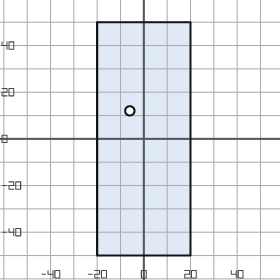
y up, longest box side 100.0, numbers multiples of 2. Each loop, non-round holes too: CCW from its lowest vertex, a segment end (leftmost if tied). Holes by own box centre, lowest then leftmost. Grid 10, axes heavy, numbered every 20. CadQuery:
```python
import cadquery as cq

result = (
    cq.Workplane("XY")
    .moveTo(-20.0, -50.0)
    .lineTo(20.0, -50.0)
    .lineTo(20.0, 50.0)
    .lineTo(-20.0, 50.0)
    .close()
    .moveTo(-6.0, 12.0)
    .circle(2.0)
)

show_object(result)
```